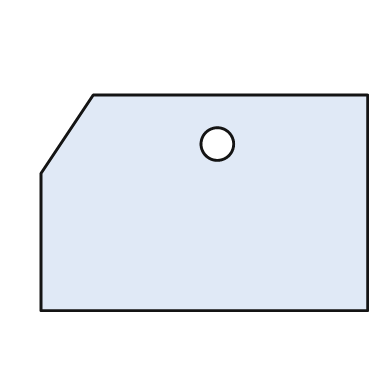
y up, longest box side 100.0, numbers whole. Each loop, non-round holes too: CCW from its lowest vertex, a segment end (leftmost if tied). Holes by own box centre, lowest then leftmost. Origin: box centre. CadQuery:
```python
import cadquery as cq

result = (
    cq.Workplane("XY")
    .moveTo(-50.0, -33.0)
    .lineTo(50.0, -33.0)
    .lineTo(50.0, 33.0)
    .lineTo(-34.0, 33.0)
    .lineTo(-50.0, 9.0)
    .close()
    .moveTo(4.0, 18.0)
    .circle(5.0)
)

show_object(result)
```